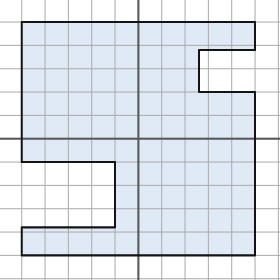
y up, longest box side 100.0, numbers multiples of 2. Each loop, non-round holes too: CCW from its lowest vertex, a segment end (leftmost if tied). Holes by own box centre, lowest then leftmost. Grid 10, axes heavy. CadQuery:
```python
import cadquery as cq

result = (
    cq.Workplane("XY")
    .moveTo(-50.0, -50.0)
    .lineTo(50.0, -50.0)
    .lineTo(50.0, 20.0)
    .lineTo(26.0, 20.0)
    .lineTo(26.0, 38.0)
    .lineTo(50.0, 38.0)
    .lineTo(50.0, 50.0)
    .lineTo(-50.0, 50.0)
    .lineTo(-50.0, -10.0)
    .lineTo(-10.0, -10.0)
    .lineTo(-10.0, -38.0)
    .lineTo(-50.0, -38.0)
    .close()
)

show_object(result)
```